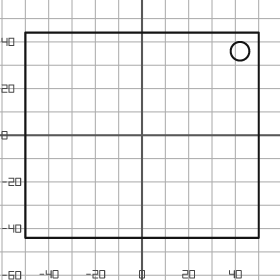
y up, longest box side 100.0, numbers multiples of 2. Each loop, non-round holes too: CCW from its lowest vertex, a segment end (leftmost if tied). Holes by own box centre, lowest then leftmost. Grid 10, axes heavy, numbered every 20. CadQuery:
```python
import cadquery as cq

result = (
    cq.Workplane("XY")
    .moveTo(-50.0, -44.0)
    .lineTo(50.0, -44.0)
    .lineTo(50.0, 44.0)
    .lineTo(-50.0, 44.0)
    .close()
    .moveTo(42.0, 36.0)
    .circle(4.0)
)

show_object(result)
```